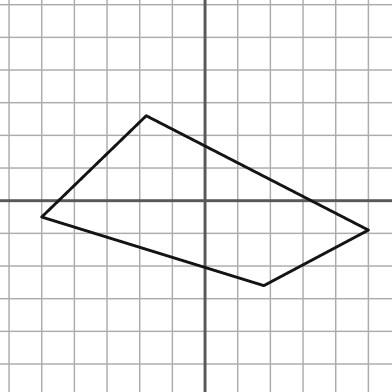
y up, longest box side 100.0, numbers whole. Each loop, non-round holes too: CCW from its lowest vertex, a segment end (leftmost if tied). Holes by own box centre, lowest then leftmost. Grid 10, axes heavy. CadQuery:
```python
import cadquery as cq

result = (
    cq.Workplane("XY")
    .moveTo(18.0, -26.0)
    .lineTo(50.0, -9.0)
    .lineTo(-18.0, 26.0)
    .lineTo(-50.0, -5.0)
    .close()
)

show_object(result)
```